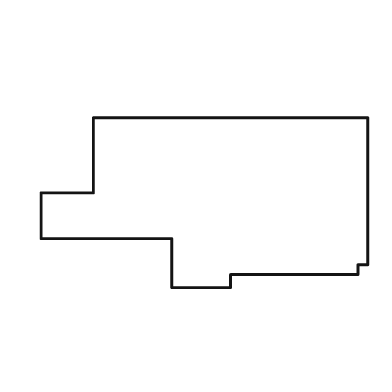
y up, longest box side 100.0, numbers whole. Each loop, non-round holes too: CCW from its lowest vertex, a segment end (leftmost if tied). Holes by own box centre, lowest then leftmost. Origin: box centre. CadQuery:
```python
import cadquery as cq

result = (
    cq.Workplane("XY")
    .moveTo(-10.0, -26.0)
    .lineTo(8.0, -26.0)
    .lineTo(8.0, -22.0)
    .lineTo(47.0, -22.0)
    .lineTo(47.0, -19.0)
    .lineTo(50.0, -19.0)
    .lineTo(50.0, 26.0)
    .lineTo(-34.0, 26.0)
    .lineTo(-34.0, 3.0)
    .lineTo(-50.0, 3.0)
    .lineTo(-50.0, -11.0)
    .lineTo(-10.0, -11.0)
    .close()
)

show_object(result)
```